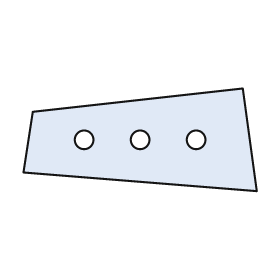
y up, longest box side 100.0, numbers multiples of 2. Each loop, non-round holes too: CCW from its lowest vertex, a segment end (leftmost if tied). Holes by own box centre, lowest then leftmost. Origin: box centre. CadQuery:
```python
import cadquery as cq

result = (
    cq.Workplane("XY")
    .moveTo(50.0, -22.0)
    .lineTo(44.0, 22.0)
    .lineTo(-46.0, 12.0)
    .lineTo(-50.0, -14.0)
    .close()
    .moveTo(-24.0, 0.0)
    .circle(4.0)
    .moveTo(0.0, 0.0)
    .circle(4.0)
    .moveTo(24.0, 0.0)
    .circle(4.0)
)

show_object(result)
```